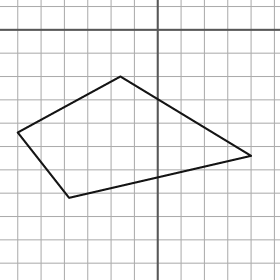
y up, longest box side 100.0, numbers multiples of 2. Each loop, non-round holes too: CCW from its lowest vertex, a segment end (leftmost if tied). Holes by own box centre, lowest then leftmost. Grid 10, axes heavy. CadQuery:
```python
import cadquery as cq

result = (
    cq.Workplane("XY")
    .moveTo(-38.0, -72.0)
    .lineTo(40.0, -54.0)
    .lineTo(-16.0, -20.0)
    .lineTo(-60.0, -44.0)
    .close()
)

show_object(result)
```